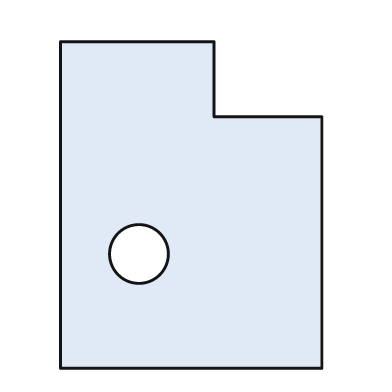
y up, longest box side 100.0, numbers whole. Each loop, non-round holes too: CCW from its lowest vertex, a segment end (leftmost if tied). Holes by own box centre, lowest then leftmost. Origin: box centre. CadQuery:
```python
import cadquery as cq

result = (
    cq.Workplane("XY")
    .moveTo(-40.0, -50.0)
    .lineTo(40.0, -50.0)
    .lineTo(40.0, 27.0)
    .lineTo(7.0, 27.0)
    .lineTo(7.0, 50.0)
    .lineTo(-40.0, 50.0)
    .close()
    .moveTo(-16.0, -15.0)
    .circle(9.0)
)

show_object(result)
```